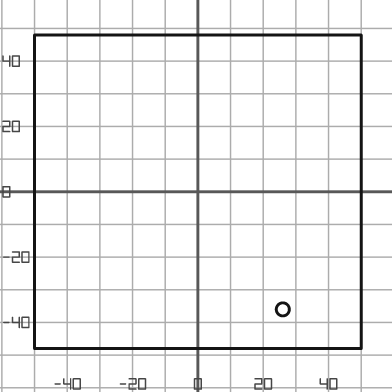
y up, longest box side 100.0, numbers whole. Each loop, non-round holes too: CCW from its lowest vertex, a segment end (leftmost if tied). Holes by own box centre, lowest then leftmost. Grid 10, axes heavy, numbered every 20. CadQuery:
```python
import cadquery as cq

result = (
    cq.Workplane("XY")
    .moveTo(-50.0, -48.0)
    .lineTo(50.0, -48.0)
    .lineTo(50.0, 48.0)
    .lineTo(-50.0, 48.0)
    .close()
    .moveTo(26.0, -36.0)
    .circle(2.0)
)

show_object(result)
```